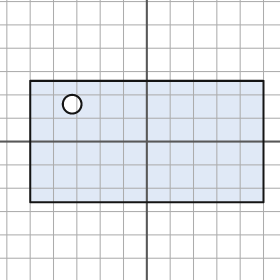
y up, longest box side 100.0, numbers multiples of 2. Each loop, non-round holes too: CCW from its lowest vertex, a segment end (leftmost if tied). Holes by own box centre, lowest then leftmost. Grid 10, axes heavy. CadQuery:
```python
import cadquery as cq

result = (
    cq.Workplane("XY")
    .moveTo(-50.0, -26.0)
    .lineTo(50.0, -26.0)
    .lineTo(50.0, 26.0)
    .lineTo(-50.0, 26.0)
    .close()
    .moveTo(-32.0, 16.0)
    .circle(4.0)
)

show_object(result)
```